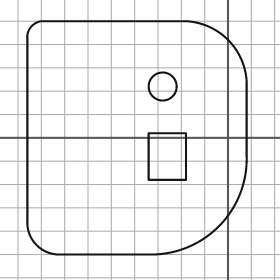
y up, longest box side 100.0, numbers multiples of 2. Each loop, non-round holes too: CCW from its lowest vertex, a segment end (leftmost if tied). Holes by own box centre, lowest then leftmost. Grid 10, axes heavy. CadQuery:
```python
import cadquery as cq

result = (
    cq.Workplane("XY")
    .moveTo(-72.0, -50.0)
    .lineTo(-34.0, -50.0)
    .threePointArc((-4.0, -38.0), (8.0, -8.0))
    .lineTo(8.0, 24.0)
    .threePointArc((0.0, 42.0), (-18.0, 50.0))
    .lineTo(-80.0, 50.0)
    .threePointArc((-84.0, 48.0), (-86.0, 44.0))
    .lineTo(-86.0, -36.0)
    .threePointArc((-82.0, -46.0), (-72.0, -50.0))
    .close()
    .moveTo(-34.0, -18.0)
    .lineTo(-18.0, -18.0)
    .lineTo(-18.0, 2.0)
    .lineTo(-34.0, 2.0)
    .close()
    .moveTo(-28.0, 22.0)
    .circle(6.0)
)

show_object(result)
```